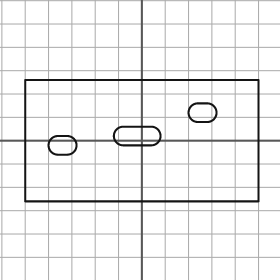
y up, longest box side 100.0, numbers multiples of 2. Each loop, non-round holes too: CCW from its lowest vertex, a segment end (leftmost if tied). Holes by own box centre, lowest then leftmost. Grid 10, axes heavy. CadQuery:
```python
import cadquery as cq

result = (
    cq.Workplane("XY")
    .moveTo(-50.0, -26.0)
    .lineTo(50.0, -26.0)
    .lineTo(50.0, 26.0)
    .lineTo(-50.0, 26.0)
    .close()
    .moveTo(-36.0, -6.0)
    .lineTo(-32.0, -6.0)
    .threePointArc((-28.0, -2.0), (-32.0, 2.0))
    .lineTo(-36.0, 2.0)
    .threePointArc((-40.0, -2.0), (-36.0, -6.0))
    .close()
    .moveTo(-8.0, -2.0)
    .lineTo(4.0, -2.0)
    .threePointArc((8.0, 2.0), (4.0, 6.0))
    .lineTo(-8.0, 6.0)
    .threePointArc((-12.0, 2.0), (-8.0, -2.0))
    .close()
    .moveTo(24.0, 8.0)
    .lineTo(28.0, 8.0)
    .threePointArc((32.0, 12.0), (28.0, 16.0))
    .lineTo(24.0, 16.0)
    .threePointArc((20.0, 12.0), (24.0, 8.0))
    .close()
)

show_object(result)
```